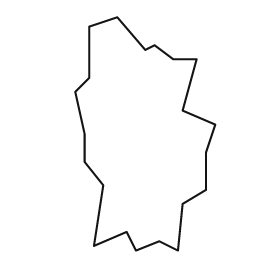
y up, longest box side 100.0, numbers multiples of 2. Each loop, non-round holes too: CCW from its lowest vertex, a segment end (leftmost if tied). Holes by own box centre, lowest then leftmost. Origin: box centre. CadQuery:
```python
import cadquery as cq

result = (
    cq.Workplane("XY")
    .moveTo(-4.0, -50.0)
    .lineTo(6.0, -46.0)
    .lineTo(14.0, -50.0)
    .lineTo(16.0, -30.0)
    .lineTo(26.0, -24.0)
    .lineTo(26.0, -8.0)
    .lineTo(30.0, 4.0)
    .lineTo(16.0, 10.0)
    .lineTo(22.0, 32.0)
    .lineTo(12.0, 32.0)
    .lineTo(4.0, 38.0)
    .lineTo(0.0, 36.0)
    .lineTo(-12.0, 50.0)
    .lineTo(-24.0, 46.0)
    .lineTo(-24.0, 24.0)
    .lineTo(-30.0, 18.0)
    .lineTo(-26.0, 0.0)
    .lineTo(-26.0, -12.0)
    .lineTo(-18.0, -22.0)
    .lineTo(-22.0, -48.0)
    .lineTo(-8.0, -42.0)
    .close()
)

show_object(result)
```